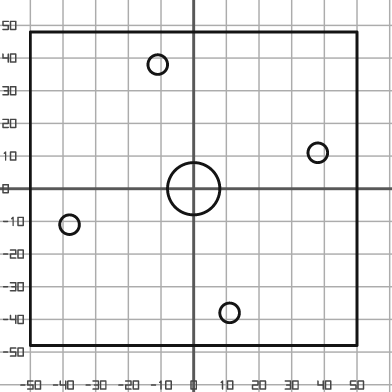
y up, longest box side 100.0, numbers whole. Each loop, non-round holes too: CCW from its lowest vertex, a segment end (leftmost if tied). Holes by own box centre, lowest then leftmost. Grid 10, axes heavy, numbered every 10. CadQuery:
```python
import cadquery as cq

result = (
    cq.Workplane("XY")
    .moveTo(-50.0, -48.0)
    .lineTo(50.0, -48.0)
    .lineTo(50.0, 48.0)
    .lineTo(-50.0, 48.0)
    .close()
    .moveTo(11.0, -38.0)
    .circle(3.0)
    .moveTo(-38.0, -11.0)
    .circle(3.0)
    .moveTo(0.0, 0.0)
    .circle(8.0)
    .moveTo(38.0, 11.0)
    .circle(3.0)
    .moveTo(-11.0, 38.0)
    .circle(3.0)
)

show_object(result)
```